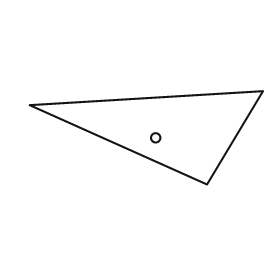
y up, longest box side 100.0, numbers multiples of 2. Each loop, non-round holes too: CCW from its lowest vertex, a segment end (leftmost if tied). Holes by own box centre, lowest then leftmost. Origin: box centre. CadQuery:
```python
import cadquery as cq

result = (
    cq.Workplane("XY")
    .moveTo(26.0, -20.0)
    .lineTo(50.0, 20.0)
    .lineTo(-50.0, 14.0)
    .close()
    .moveTo(4.0, 0.0)
    .circle(2.0)
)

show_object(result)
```